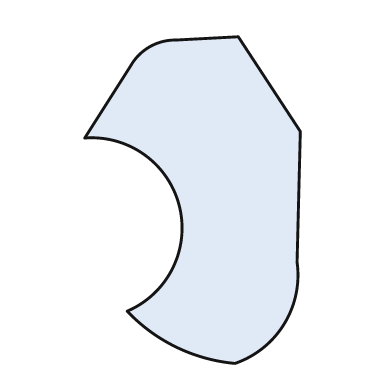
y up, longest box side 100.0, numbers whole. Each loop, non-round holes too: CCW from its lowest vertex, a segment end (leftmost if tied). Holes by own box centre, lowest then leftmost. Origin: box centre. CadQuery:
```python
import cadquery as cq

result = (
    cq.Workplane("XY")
    .moveTo(13.0, -50.0)
    .threePointArc((28.0, -38.0), (32.0, -19.0))
    .lineTo(33.0, 21.0)
    .lineTo(14.0, 50.0)
    .lineTo(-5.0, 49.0)
    .threePointArc((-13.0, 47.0), (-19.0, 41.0))
    .lineTo(-33.0, 19.0)
    .threePointArc((-4.0, -2.0), (-20.0, -34.0))
    .threePointArc((-5.0, -45.0), (13.0, -50.0))
    .close()
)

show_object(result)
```